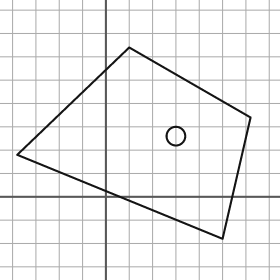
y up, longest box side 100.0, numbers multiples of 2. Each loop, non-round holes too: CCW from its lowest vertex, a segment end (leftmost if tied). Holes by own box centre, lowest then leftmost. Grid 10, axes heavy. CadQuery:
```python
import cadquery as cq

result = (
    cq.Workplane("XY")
    .moveTo(50.0, -18.0)
    .lineTo(62.0, 34.0)
    .lineTo(10.0, 64.0)
    .lineTo(-38.0, 18.0)
    .close()
    .moveTo(30.0, 26.0)
    .circle(4.0)
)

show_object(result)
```